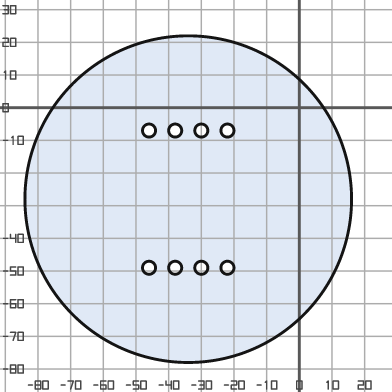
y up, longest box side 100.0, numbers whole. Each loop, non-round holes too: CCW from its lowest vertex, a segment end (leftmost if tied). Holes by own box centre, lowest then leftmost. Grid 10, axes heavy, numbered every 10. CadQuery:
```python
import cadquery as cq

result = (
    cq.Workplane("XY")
    .moveTo(-34.0, -28.0)
    .circle(50.0)
    .moveTo(-46.0, -49.0)
    .circle(2.0)
    .moveTo(-38.0, -49.0)
    .circle(2.0)
    .moveTo(-30.0, -49.0)
    .circle(2.0)
    .moveTo(-22.0, -49.0)
    .circle(2.0)
    .moveTo(-46.0, -7.0)
    .circle(2.0)
    .moveTo(-38.0, -7.0)
    .circle(2.0)
    .moveTo(-30.0, -7.0)
    .circle(2.0)
    .moveTo(-22.0, -7.0)
    .circle(2.0)
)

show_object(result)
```